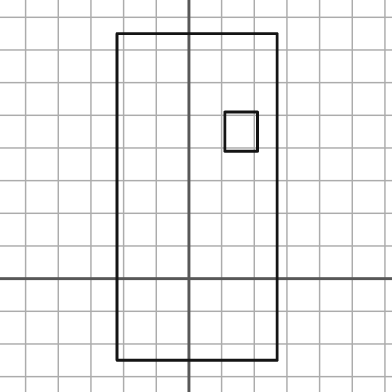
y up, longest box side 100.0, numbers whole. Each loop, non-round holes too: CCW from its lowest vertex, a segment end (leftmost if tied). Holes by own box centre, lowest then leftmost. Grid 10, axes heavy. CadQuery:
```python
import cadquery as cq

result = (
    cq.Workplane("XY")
    .moveTo(-22.0, -25.0)
    .lineTo(27.0, -25.0)
    .lineTo(27.0, 75.0)
    .lineTo(-22.0, 75.0)
    .close()
    .moveTo(11.0, 39.0)
    .lineTo(21.0, 39.0)
    .lineTo(21.0, 51.0)
    .lineTo(11.0, 51.0)
    .close()
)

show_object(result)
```